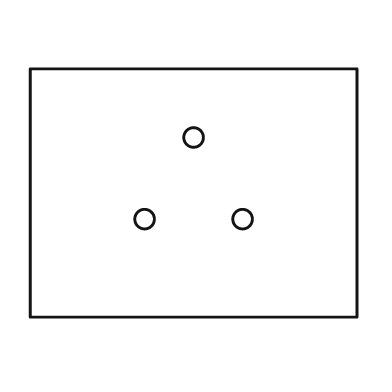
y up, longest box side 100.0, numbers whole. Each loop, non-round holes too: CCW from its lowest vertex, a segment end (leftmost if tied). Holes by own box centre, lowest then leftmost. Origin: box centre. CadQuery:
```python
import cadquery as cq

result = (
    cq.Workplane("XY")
    .moveTo(-50.0, -38.0)
    .lineTo(50.0, -38.0)
    .lineTo(50.0, 38.0)
    .lineTo(-50.0, 38.0)
    .close()
    .moveTo(-15.0, -8.0)
    .circle(3.0)
    .moveTo(15.0, -8.0)
    .circle(3.0)
    .moveTo(0.0, 17.0)
    .circle(3.0)
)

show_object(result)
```